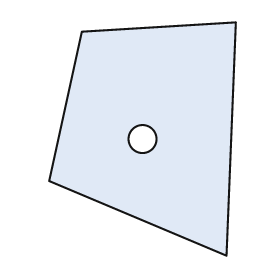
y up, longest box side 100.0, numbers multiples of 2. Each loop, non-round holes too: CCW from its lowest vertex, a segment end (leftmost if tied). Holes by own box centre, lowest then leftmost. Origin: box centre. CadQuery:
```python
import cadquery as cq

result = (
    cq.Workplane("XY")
    .moveTo(36.0, -50.0)
    .lineTo(40.0, 50.0)
    .lineTo(-26.0, 46.0)
    .lineTo(-40.0, -18.0)
    .close()
    .moveTo(0.0, 0.0)
    .circle(6.0)
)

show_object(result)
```